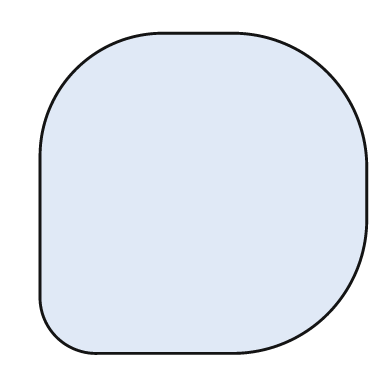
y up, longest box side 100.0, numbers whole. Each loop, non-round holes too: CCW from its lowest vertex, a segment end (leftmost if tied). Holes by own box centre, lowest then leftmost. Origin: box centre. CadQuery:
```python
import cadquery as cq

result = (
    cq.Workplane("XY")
    .moveTo(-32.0, -49.0)
    .lineTo(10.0, -49.0)
    .threePointArc((38.0, -37.0), (50.0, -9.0))
    .lineTo(50.0, 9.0)
    .threePointArc((38.0, 37.0), (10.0, 49.0))
    .lineTo(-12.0, 49.0)
    .threePointArc((-39.0, 38.0), (-50.0, 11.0))
    .lineTo(-50.0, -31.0)
    .threePointArc((-45.0, -44.0), (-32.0, -49.0))
    .close()
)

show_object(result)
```